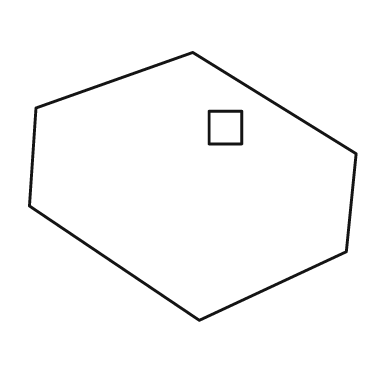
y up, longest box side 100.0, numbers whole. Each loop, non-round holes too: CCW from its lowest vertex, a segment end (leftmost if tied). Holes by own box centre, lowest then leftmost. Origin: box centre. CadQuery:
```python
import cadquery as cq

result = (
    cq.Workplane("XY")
    .moveTo(2.0, -41.0)
    .lineTo(47.0, -20.0)
    .lineTo(50.0, 10.0)
    .lineTo(0.0, 41.0)
    .lineTo(-48.0, 24.0)
    .lineTo(-50.0, -6.0)
    .close()
    .moveTo(5.0, 13.0)
    .lineTo(15.0, 13.0)
    .lineTo(15.0, 23.0)
    .lineTo(5.0, 23.0)
    .close()
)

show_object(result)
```